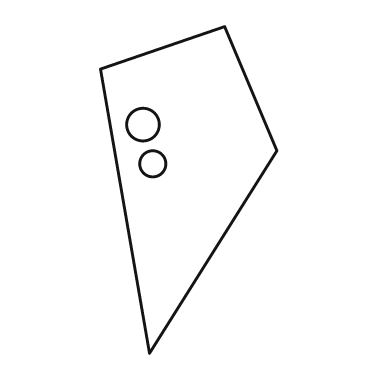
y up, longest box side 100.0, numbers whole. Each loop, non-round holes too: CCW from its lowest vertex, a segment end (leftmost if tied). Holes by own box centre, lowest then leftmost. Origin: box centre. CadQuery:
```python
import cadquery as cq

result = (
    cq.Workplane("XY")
    .moveTo(-12.0, -50.0)
    .lineTo(27.0, 12.0)
    .lineTo(11.0, 50.0)
    .lineTo(-27.0, 37.0)
    .close()
    .moveTo(-11.0, 8.0)
    .circle(4.0)
    .moveTo(-14.0, 20.0)
    .circle(5.0)
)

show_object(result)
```